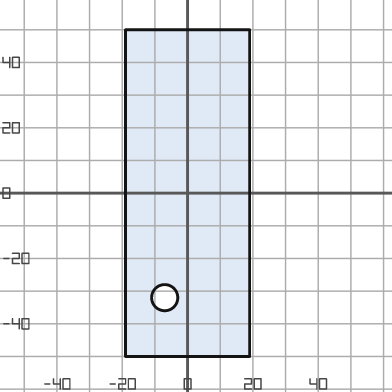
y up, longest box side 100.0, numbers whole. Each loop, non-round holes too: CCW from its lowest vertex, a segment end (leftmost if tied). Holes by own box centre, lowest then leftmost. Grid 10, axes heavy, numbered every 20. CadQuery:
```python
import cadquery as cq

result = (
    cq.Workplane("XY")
    .moveTo(-19.0, -50.0)
    .lineTo(19.0, -50.0)
    .lineTo(19.0, 50.0)
    .lineTo(-19.0, 50.0)
    .close()
    .moveTo(-7.0, -32.0)
    .circle(4.0)
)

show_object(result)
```